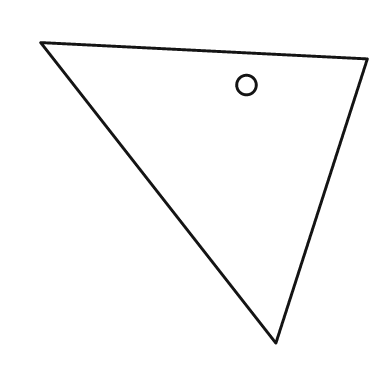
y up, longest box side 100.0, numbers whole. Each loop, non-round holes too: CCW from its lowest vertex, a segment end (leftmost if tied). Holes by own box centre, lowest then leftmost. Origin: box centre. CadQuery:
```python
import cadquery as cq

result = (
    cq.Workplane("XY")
    .moveTo(22.0, -46.0)
    .lineTo(50.0, 41.0)
    .lineTo(-50.0, 46.0)
    .close()
    .moveTo(13.0, 33.0)
    .circle(3.0)
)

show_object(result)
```